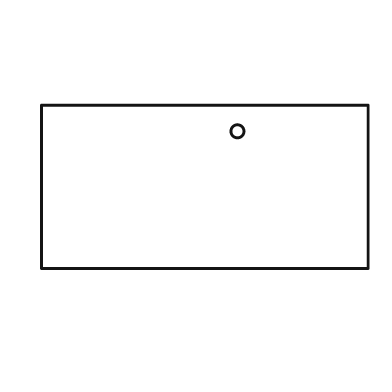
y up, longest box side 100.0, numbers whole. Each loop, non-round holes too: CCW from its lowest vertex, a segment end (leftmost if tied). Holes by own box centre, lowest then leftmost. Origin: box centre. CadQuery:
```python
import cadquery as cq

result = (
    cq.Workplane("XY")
    .moveTo(-50.0, -25.0)
    .lineTo(50.0, -25.0)
    .lineTo(50.0, 25.0)
    .lineTo(-50.0, 25.0)
    .close()
    .moveTo(10.0, 17.0)
    .circle(2.0)
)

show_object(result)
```